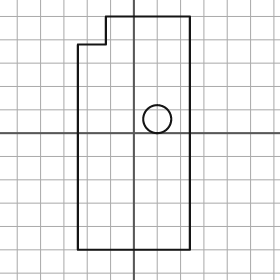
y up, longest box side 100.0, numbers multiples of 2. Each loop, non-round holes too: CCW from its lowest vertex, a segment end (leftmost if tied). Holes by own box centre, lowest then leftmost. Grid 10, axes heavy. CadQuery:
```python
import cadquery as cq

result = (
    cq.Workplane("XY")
    .moveTo(-24.0, -50.0)
    .lineTo(24.0, -50.0)
    .lineTo(24.0, 50.0)
    .lineTo(-12.0, 50.0)
    .lineTo(-12.0, 38.0)
    .lineTo(-24.0, 38.0)
    .close()
    .moveTo(10.0, 6.0)
    .circle(6.0)
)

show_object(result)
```